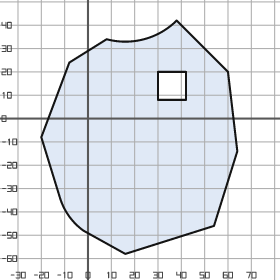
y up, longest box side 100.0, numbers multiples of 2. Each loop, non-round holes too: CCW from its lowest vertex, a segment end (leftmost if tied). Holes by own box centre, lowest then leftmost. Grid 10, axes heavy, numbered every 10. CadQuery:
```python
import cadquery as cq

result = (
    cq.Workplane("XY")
    .moveTo(16.0, -58.0)
    .lineTo(54.0, -46.0)
    .lineTo(64.0, -14.0)
    .lineTo(60.0, 20.0)
    .lineTo(38.0, 42.0)
    .threePointArc((24.0, 34.0), (8.0, 34.0))
    .lineTo(-8.0, 24.0)
    .lineTo(-20.0, -8.0)
    .lineTo(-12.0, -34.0)
    .threePointArc((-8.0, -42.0), (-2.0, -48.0))
    .close()
    .moveTo(30.0, 8.0)
    .lineTo(42.0, 8.0)
    .lineTo(42.0, 20.0)
    .lineTo(30.0, 20.0)
    .close()
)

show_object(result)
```